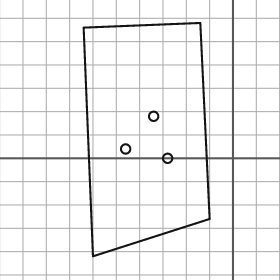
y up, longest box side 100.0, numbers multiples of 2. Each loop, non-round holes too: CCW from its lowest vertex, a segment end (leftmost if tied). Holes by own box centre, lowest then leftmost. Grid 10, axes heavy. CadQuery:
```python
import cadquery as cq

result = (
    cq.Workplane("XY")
    .moveTo(-60.0, -42.0)
    .lineTo(-10.0, -26.0)
    .lineTo(-14.0, 58.0)
    .lineTo(-64.0, 56.0)
    .close()
    .moveTo(-28.0, 0.0)
    .circle(2.0)
    .moveTo(-46.0, 4.0)
    .circle(2.0)
    .moveTo(-34.0, 18.0)
    .circle(2.0)
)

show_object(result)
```